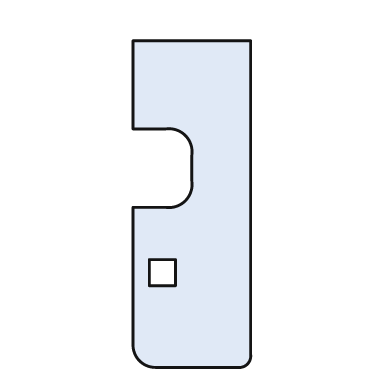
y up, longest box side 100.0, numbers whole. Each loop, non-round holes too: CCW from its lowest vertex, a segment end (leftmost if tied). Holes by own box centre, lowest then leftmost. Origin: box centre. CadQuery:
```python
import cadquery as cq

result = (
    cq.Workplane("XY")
    .moveTo(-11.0, -50.0)
    .lineTo(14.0, -50.0)
    .threePointArc((17.0, -49.0), (18.0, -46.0))
    .lineTo(18.0, 50.0)
    .lineTo(-18.0, 50.0)
    .lineTo(-18.0, 23.0)
    .lineTo(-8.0, 23.0)
    .threePointArc((-2.0, 21.0), (0.0, 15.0))
    .lineTo(0.0, 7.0)
    .threePointArc((-2.0, 1.0), (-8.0, -1.0))
    .lineTo(-18.0, -1.0)
    .lineTo(-18.0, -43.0)
    .threePointArc((-16.0, -48.0), (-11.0, -50.0))
    .close()
    .moveTo(-13.0, -25.0)
    .lineTo(-5.0, -25.0)
    .lineTo(-5.0, -17.0)
    .lineTo(-13.0, -17.0)
    .close()
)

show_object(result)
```